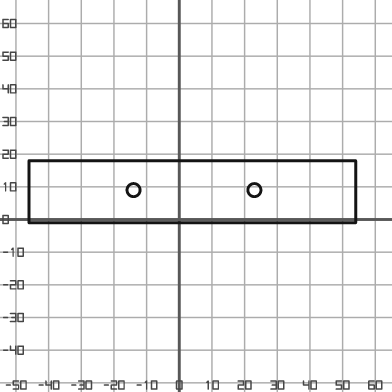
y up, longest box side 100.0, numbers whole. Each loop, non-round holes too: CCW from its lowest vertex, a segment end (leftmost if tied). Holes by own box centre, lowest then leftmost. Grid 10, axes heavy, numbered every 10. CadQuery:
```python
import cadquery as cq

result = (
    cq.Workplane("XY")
    .moveTo(-46.0, -1.0)
    .lineTo(54.0, -1.0)
    .lineTo(54.0, 18.0)
    .lineTo(-46.0, 18.0)
    .close()
    .moveTo(-14.0, 9.0)
    .circle(2.0)
    .moveTo(23.0, 9.0)
    .circle(2.0)
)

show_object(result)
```